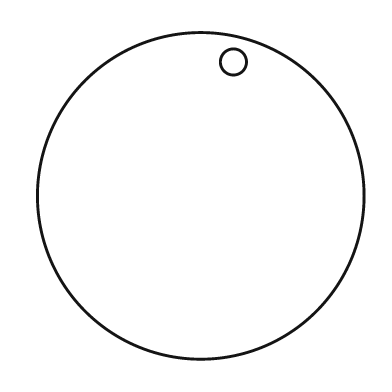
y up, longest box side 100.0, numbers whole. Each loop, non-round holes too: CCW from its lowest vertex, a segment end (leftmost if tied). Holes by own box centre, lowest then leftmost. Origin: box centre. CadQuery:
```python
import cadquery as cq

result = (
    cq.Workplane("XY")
    .moveTo(0.0, 0.0)
    .circle(50.0)
    .moveTo(10.0, 41.0)
    .circle(4.0)
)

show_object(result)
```